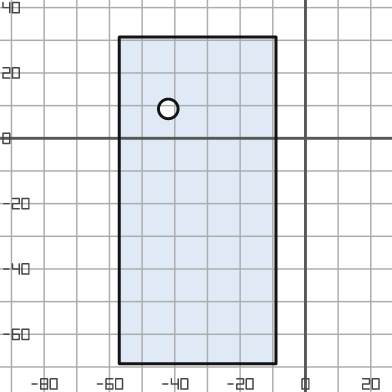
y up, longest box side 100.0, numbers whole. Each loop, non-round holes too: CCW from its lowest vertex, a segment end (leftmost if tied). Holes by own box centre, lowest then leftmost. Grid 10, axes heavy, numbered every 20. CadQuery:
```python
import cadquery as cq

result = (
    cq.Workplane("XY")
    .moveTo(-57.0, -69.0)
    .lineTo(-9.0, -69.0)
    .lineTo(-9.0, 31.0)
    .lineTo(-57.0, 31.0)
    .close()
    .moveTo(-42.0, 9.0)
    .circle(3.0)
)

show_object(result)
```